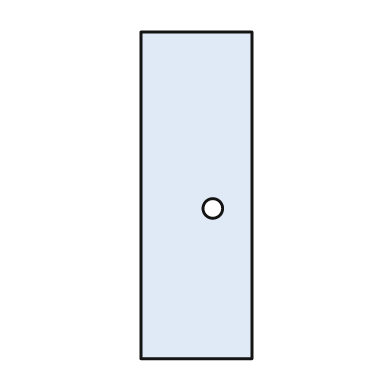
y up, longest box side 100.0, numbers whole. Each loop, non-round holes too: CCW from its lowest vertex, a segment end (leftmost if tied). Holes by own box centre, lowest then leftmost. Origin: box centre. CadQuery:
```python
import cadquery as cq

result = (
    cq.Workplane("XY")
    .moveTo(-17.0, -50.0)
    .lineTo(17.0, -50.0)
    .lineTo(17.0, 50.0)
    .lineTo(-17.0, 50.0)
    .close()
    .moveTo(5.0, -4.0)
    .circle(3.0)
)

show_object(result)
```